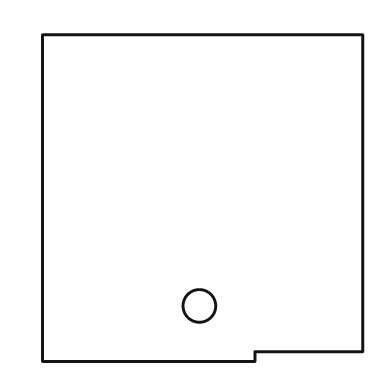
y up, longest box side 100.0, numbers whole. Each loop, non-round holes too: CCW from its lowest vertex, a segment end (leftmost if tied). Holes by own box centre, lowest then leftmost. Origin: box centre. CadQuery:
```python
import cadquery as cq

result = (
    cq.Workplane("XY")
    .moveTo(-49.0, -50.0)
    .lineTo(16.0, -50.0)
    .lineTo(16.0, -47.0)
    .lineTo(49.0, -47.0)
    .lineTo(49.0, 50.0)
    .lineTo(-49.0, 50.0)
    .close()
    .moveTo(-1.0, -33.0)
    .circle(5.0)
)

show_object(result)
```